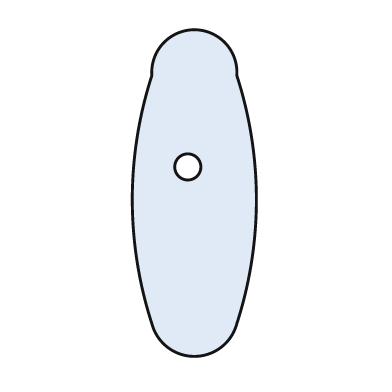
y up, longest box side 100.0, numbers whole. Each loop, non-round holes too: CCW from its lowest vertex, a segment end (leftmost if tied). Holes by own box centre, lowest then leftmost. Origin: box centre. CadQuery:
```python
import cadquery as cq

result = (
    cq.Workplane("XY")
    .moveTo(-13.0, -40.0)
    .threePointArc((0.0, -50.0), (13.0, -40.0))
    .threePointArc((19.0, -2.0), (13.0, 36.0))
    .threePointArc((0.0, 50.0), (-13.0, 36.0))
    .threePointArc((-19.0, -2.0), (-13.0, -40.0))
    .close()
    .moveTo(-2.0, 8.0)
    .circle(4.0)
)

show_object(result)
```